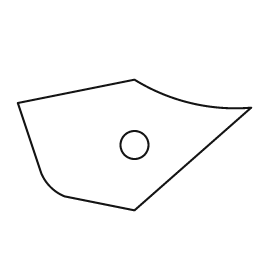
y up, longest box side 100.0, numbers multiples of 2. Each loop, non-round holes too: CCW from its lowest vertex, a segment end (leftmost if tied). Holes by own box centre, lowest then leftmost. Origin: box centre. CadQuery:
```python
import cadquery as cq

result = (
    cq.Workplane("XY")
    .moveTo(0.0, -28.0)
    .lineTo(50.0, 16.0)
    .threePointArc((24.0, 18.0), (0.0, 28.0))
    .lineTo(-50.0, 18.0)
    .lineTo(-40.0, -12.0)
    .threePointArc((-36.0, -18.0), (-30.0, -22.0))
    .close()
    .moveTo(0.0, 0.0)
    .circle(6.0)
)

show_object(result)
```